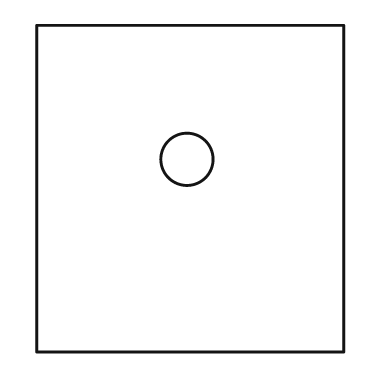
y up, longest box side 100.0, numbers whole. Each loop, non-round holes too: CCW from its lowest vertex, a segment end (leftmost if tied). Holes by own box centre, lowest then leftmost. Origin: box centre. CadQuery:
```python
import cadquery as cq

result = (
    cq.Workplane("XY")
    .moveTo(-47.0, -50.0)
    .lineTo(47.0, -50.0)
    .lineTo(47.0, 50.0)
    .lineTo(-47.0, 50.0)
    .close()
    .moveTo(-1.0, 9.0)
    .circle(8.0)
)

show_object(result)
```